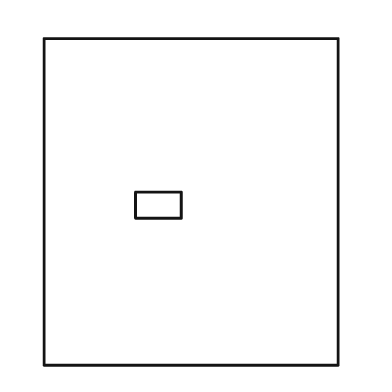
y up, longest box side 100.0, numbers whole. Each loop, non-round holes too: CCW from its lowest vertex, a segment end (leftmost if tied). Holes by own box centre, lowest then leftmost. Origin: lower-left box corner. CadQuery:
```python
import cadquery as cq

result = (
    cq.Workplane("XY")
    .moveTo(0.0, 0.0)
    .lineTo(90.0, 0.0)
    .lineTo(90.0, 100.0)
    .lineTo(0.0, 100.0)
    .close()
    .moveTo(28.0, 45.0)
    .lineTo(42.0, 45.0)
    .lineTo(42.0, 53.0)
    .lineTo(28.0, 53.0)
    .close()
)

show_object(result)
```